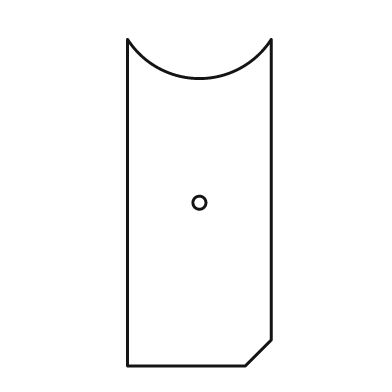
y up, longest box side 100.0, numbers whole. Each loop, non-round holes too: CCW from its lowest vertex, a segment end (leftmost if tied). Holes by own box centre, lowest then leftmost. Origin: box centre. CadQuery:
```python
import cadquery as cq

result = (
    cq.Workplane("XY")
    .moveTo(-22.0, -50.0)
    .lineTo(14.0, -50.0)
    .lineTo(22.0, -42.0)
    .lineTo(22.0, 50.0)
    .threePointArc((0.0, 38.0), (-22.0, 50.0))
    .close()
    .moveTo(0.0, 0.0)
    .circle(2.0)
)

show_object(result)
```